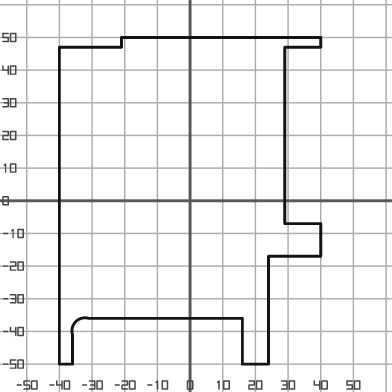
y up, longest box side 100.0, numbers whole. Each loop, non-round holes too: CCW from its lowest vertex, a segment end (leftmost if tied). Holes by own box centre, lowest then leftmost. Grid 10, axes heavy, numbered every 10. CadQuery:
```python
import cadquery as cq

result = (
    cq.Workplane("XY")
    .moveTo(-40.0, -50.0)
    .lineTo(-36.0, -50.0)
    .lineTo(-36.0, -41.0)
    .threePointArc((-35.0, -37.0), (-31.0, -36.0))
    .lineTo(16.0, -36.0)
    .lineTo(16.0, -50.0)
    .lineTo(24.0, -50.0)
    .lineTo(24.0, -17.0)
    .lineTo(40.0, -17.0)
    .lineTo(40.0, -7.0)
    .lineTo(29.0, -7.0)
    .lineTo(29.0, 47.0)
    .lineTo(40.0, 47.0)
    .lineTo(40.0, 50.0)
    .lineTo(-21.0, 50.0)
    .lineTo(-21.0, 47.0)
    .lineTo(-40.0, 47.0)
    .close()
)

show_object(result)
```